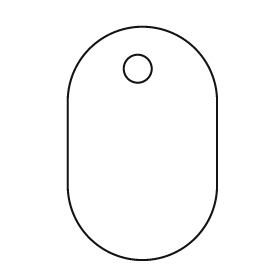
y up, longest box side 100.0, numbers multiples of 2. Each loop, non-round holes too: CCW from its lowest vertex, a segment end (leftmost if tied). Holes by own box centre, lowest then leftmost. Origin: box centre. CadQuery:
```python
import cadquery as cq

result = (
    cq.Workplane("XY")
    .moveTo(-32.0, -18.0)
    .threePointArc((0.0, -50.0), (32.0, -18.0))
    .lineTo(32.0, 18.0)
    .threePointArc((0.0, 50.0), (-32.0, 18.0))
    .close()
    .moveTo(-2.0, 32.0)
    .circle(6.0)
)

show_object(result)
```